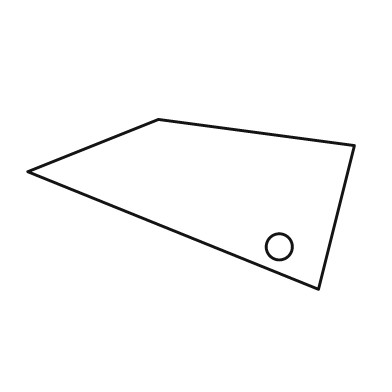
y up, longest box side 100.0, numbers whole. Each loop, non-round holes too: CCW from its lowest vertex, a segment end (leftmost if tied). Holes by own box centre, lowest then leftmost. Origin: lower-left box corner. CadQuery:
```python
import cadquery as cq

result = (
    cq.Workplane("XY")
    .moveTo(89.0, 0.0)
    .lineTo(100.0, 44.0)
    .lineTo(40.0, 52.0)
    .lineTo(0.0, 36.0)
    .close()
    .moveTo(77.0, 13.0)
    .circle(4.0)
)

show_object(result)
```